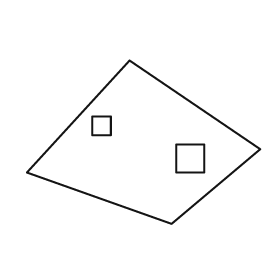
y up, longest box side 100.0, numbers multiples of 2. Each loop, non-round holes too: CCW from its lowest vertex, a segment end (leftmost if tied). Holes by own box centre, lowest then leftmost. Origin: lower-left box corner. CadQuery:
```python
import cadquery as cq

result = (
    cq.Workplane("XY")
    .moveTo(62.0, 0.0)
    .lineTo(100.0, 32.0)
    .lineTo(44.0, 70.0)
    .lineTo(0.0, 22.0)
    .close()
    .moveTo(64.0, 22.0)
    .lineTo(76.0, 22.0)
    .lineTo(76.0, 34.0)
    .lineTo(64.0, 34.0)
    .close()
    .moveTo(28.0, 38.0)
    .lineTo(36.0, 38.0)
    .lineTo(36.0, 46.0)
    .lineTo(28.0, 46.0)
    .close()
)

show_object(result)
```